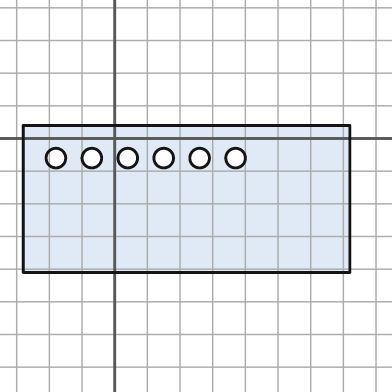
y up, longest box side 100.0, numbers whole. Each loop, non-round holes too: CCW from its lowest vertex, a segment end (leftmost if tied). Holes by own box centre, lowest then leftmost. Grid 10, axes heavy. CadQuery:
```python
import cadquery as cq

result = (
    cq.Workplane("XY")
    .moveTo(-28.0, -41.0)
    .lineTo(72.0, -41.0)
    .lineTo(72.0, 4.0)
    .lineTo(-28.0, 4.0)
    .close()
    .moveTo(-18.0, -6.0)
    .circle(3.0)
    .moveTo(-7.0, -6.0)
    .circle(3.0)
    .moveTo(4.0, -6.0)
    .circle(3.0)
    .moveTo(15.0, -6.0)
    .circle(3.0)
    .moveTo(26.0, -6.0)
    .circle(3.0)
    .moveTo(37.0, -6.0)
    .circle(3.0)
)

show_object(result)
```